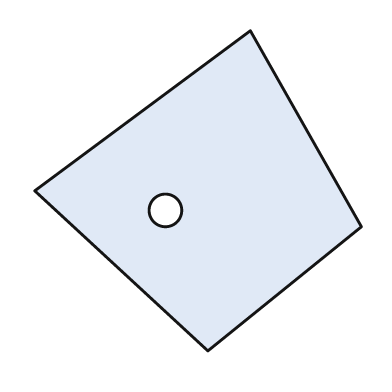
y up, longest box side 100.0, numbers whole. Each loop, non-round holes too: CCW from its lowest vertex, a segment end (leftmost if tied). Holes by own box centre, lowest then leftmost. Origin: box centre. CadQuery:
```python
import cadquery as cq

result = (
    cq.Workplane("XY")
    .moveTo(3.0, -49.0)
    .lineTo(50.0, -11.0)
    .lineTo(16.0, 49.0)
    .lineTo(-50.0, 0.0)
    .close()
    .moveTo(-10.0, -6.0)
    .circle(5.0)
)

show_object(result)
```